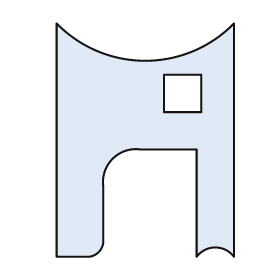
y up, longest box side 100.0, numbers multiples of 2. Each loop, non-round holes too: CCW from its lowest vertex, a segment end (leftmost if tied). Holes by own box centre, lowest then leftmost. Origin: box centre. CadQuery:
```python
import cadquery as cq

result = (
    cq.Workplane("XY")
    .moveTo(-38.0, -50.0)
    .lineTo(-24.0, -50.0)
    .threePointArc((-20.0, -48.0), (-18.0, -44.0))
    .lineTo(-18.0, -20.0)
    .threePointArc((-14.0, -8.0), (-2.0, -4.0))
    .lineTo(22.0, -4.0)
    .lineTo(22.0, -50.0)
    .threePointArc((30.0, -46.0), (38.0, -50.0))
    .lineTo(38.0, 50.0)
    .threePointArc((0.0, 34.0), (-38.0, 50.0))
    .close()
    .moveTo(8.0, 12.0)
    .lineTo(24.0, 12.0)
    .lineTo(24.0, 28.0)
    .lineTo(8.0, 28.0)
    .close()
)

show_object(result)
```